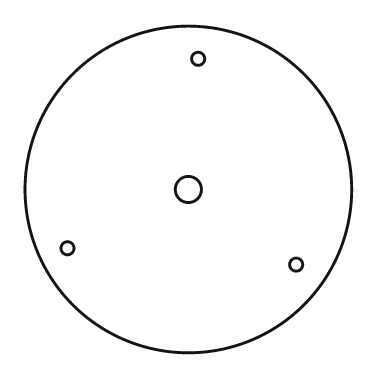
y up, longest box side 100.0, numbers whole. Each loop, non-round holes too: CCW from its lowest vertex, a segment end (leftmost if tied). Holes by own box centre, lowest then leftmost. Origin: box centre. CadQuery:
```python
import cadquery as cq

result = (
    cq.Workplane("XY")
    .moveTo(0.0, 0.0)
    .circle(50.0)
    .moveTo(33.0, -23.0)
    .circle(2.0)
    .moveTo(-37.0, -18.0)
    .circle(2.0)
    .moveTo(0.0, 0.0)
    .circle(4.0)
    .moveTo(3.0, 40.0)
    .circle(2.0)
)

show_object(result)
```